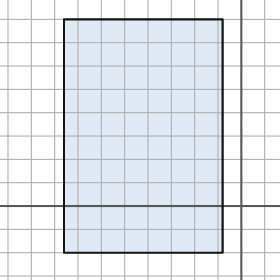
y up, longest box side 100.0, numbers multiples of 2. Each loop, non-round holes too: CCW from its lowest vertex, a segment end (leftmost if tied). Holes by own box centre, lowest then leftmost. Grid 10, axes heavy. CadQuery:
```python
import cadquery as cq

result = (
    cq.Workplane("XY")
    .moveTo(-76.0, -20.0)
    .lineTo(-8.0, -20.0)
    .lineTo(-8.0, 80.0)
    .lineTo(-76.0, 80.0)
    .close()
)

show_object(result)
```